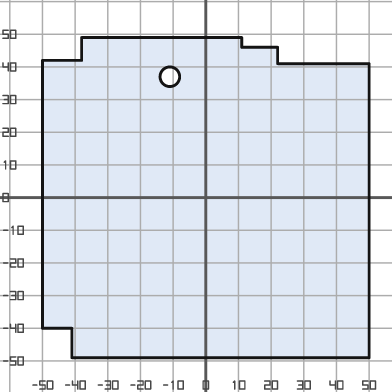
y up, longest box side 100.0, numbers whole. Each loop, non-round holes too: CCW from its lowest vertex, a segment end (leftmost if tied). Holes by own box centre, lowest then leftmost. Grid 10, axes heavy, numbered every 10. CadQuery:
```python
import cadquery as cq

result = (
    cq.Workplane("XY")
    .moveTo(-41.0, -49.0)
    .lineTo(50.0, -49.0)
    .lineTo(50.0, 41.0)
    .lineTo(22.0, 41.0)
    .lineTo(22.0, 46.0)
    .lineTo(11.0, 46.0)
    .lineTo(11.0, 49.0)
    .lineTo(-38.0, 49.0)
    .lineTo(-38.0, 42.0)
    .lineTo(-50.0, 42.0)
    .lineTo(-50.0, -40.0)
    .lineTo(-41.0, -40.0)
    .close()
    .moveTo(-11.0, 37.0)
    .circle(3.0)
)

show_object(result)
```